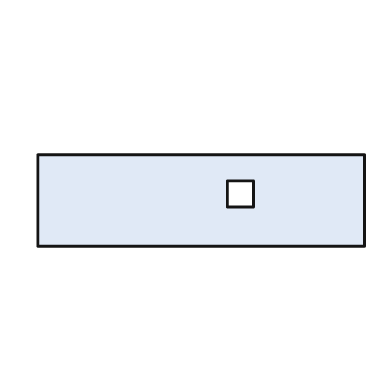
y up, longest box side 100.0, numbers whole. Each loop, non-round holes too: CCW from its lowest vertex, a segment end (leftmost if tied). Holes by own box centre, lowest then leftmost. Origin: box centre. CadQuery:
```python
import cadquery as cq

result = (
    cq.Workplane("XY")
    .moveTo(-50.0, -14.0)
    .lineTo(50.0, -14.0)
    .lineTo(50.0, 14.0)
    .lineTo(-50.0, 14.0)
    .close()
    .moveTo(8.0, -2.0)
    .lineTo(16.0, -2.0)
    .lineTo(16.0, 6.0)
    .lineTo(8.0, 6.0)
    .close()
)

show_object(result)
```